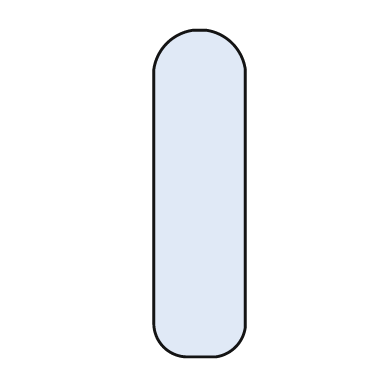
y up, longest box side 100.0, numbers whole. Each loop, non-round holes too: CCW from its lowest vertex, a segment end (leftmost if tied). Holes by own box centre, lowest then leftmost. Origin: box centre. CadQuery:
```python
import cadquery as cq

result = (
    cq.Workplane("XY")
    .moveTo(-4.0, -50.0)
    .lineTo(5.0, -50.0)
    .threePointArc((11.0, -47.0), (14.0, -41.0))
    .lineTo(14.0, 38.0)
    .threePointArc((10.0, 46.0), (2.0, 50.0))
    .lineTo(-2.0, 50.0)
    .threePointArc((-10.0, 46.0), (-14.0, 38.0))
    .lineTo(-14.0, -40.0)
    .threePointArc((-11.0, -47.0), (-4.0, -50.0))
    .close()
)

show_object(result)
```